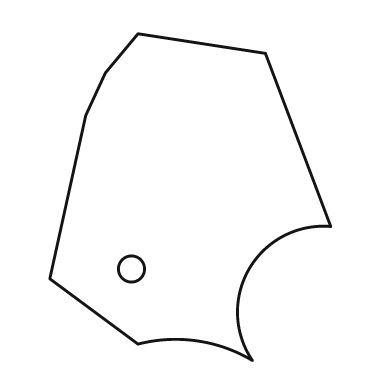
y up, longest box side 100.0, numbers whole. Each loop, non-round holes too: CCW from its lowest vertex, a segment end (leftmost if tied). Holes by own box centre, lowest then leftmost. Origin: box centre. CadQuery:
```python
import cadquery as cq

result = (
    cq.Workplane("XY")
    .moveTo(19.0, -50.0)
    .threePointArc((18.0, -22.0), (43.0, -9.0))
    .lineTo(23.0, 44.0)
    .lineTo(-16.0, 50.0)
    .lineTo(-26.0, 38.0)
    .lineTo(-32.0, 25.0)
    .lineTo(-43.0, -25.0)
    .lineTo(-16.0, -45.0)
    .threePointArc((2.0, -44.0), (19.0, -50.0))
    .close()
    .moveTo(-18.0, -22.0)
    .circle(4.0)
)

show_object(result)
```